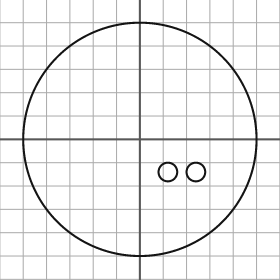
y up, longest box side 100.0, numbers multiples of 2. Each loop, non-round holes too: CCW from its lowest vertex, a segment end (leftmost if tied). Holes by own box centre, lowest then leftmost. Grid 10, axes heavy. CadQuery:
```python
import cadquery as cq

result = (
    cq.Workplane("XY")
    .moveTo(0.0, 0.0)
    .circle(50.0)
    .moveTo(12.0, -14.0)
    .circle(4.0)
    .moveTo(24.0, -14.0)
    .circle(4.0)
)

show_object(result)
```